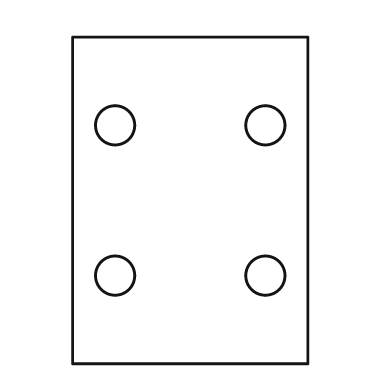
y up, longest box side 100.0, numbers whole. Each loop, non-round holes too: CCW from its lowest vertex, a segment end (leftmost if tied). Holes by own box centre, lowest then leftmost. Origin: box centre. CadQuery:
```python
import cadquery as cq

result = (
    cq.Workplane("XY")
    .moveTo(-36.0, -50.0)
    .lineTo(36.0, -50.0)
    .lineTo(36.0, 50.0)
    .lineTo(-36.0, 50.0)
    .close()
    .moveTo(-23.0, -23.0)
    .circle(6.0)
    .moveTo(23.0, -23.0)
    .circle(6.0)
    .moveTo(-23.0, 23.0)
    .circle(6.0)
    .moveTo(23.0, 23.0)
    .circle(6.0)
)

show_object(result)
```